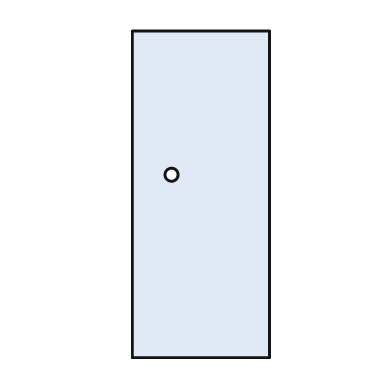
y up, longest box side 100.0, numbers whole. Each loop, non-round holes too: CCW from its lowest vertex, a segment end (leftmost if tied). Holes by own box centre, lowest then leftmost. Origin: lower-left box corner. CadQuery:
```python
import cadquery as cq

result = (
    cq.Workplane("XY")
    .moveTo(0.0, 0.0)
    .lineTo(42.0, 0.0)
    .lineTo(42.0, 100.0)
    .lineTo(0.0, 100.0)
    .close()
    .moveTo(12.0, 56.0)
    .circle(2.0)
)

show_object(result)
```